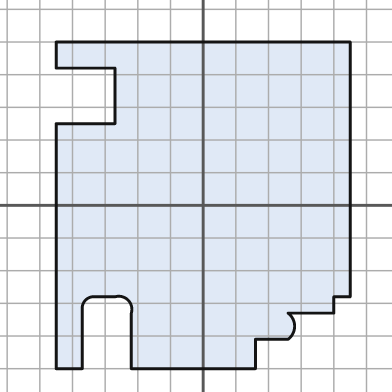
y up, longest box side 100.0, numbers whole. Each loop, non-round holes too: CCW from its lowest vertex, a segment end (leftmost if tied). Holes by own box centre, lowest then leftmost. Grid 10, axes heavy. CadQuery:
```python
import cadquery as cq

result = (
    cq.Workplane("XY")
    .moveTo(-45.0, -50.0)
    .lineTo(-37.0, -50.0)
    .lineTo(-37.0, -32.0)
    .threePointArc((-36.0, -29.0), (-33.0, -28.0))
    .lineTo(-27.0, -28.0)
    .threePointArc((-23.0, -29.0), (-22.0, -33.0))
    .lineTo(-22.0, -50.0)
    .lineTo(16.0, -50.0)
    .lineTo(16.0, -41.0)
    .lineTo(26.0, -41.0)
    .threePointArc((28.0, -37.0), (26.0, -33.0))
    .lineTo(40.0, -33.0)
    .lineTo(40.0, -28.0)
    .lineTo(45.0, -28.0)
    .lineTo(45.0, 50.0)
    .lineTo(-45.0, 50.0)
    .lineTo(-45.0, 42.0)
    .lineTo(-27.0, 42.0)
    .lineTo(-27.0, 25.0)
    .lineTo(-45.0, 25.0)
    .close()
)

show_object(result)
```